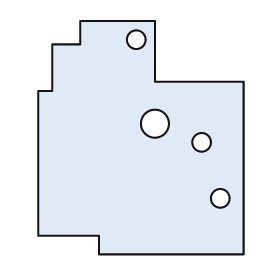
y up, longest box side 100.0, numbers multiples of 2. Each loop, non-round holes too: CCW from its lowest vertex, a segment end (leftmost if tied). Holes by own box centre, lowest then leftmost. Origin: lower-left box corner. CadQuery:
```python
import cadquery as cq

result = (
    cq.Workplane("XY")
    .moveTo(26.0, 0.0)
    .lineTo(88.0, 0.0)
    .lineTo(88.0, 74.0)
    .lineTo(50.0, 74.0)
    .lineTo(50.0, 100.0)
    .lineTo(18.0, 100.0)
    .lineTo(18.0, 90.0)
    .lineTo(6.0, 90.0)
    .lineTo(6.0, 70.0)
    .lineTo(0.0, 70.0)
    .lineTo(0.0, 8.0)
    .lineTo(26.0, 8.0)
    .close()
    .moveTo(78.0, 24.0)
    .circle(4.0)
    .moveTo(70.0, 48.0)
    .circle(4.0)
    .moveTo(50.0, 56.0)
    .circle(6.0)
    .moveTo(42.0, 92.0)
    .circle(4.0)
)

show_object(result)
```